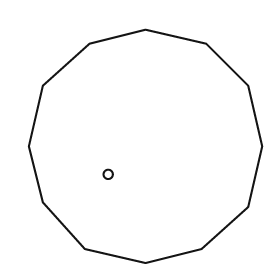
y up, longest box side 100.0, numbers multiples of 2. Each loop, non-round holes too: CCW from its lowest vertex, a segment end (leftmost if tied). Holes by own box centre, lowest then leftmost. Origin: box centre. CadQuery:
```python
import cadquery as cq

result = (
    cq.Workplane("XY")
    .moveTo(0.0, -50.0)
    .lineTo(24.0, -44.0)
    .lineTo(44.0, -26.0)
    .lineTo(50.0, 0.0)
    .lineTo(44.0, 26.0)
    .lineTo(26.0, 44.0)
    .lineTo(0.0, 50.0)
    .lineTo(-24.0, 44.0)
    .lineTo(-44.0, 26.0)
    .lineTo(-50.0, 0.0)
    .lineTo(-44.0, -24.0)
    .lineTo(-26.0, -44.0)
    .close()
    .moveTo(-16.0, -12.0)
    .circle(2.0)
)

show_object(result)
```